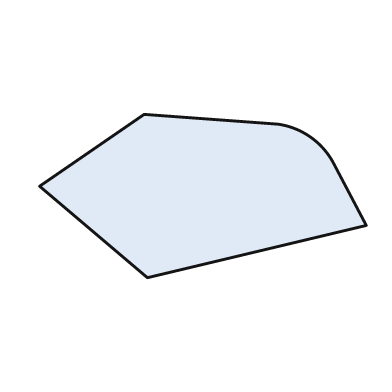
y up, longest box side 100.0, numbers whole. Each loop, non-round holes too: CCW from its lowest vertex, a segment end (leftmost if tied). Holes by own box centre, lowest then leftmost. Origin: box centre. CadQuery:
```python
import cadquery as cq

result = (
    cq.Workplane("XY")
    .moveTo(-17.0, -25.0)
    .lineTo(50.0, -9.0)
    .lineTo(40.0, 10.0)
    .threePointArc((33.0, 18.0), (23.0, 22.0))
    .lineTo(-18.0, 25.0)
    .lineTo(-50.0, 3.0)
    .close()
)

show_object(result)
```